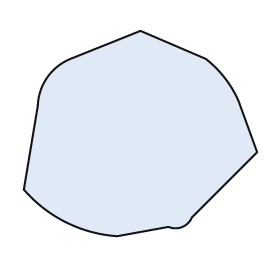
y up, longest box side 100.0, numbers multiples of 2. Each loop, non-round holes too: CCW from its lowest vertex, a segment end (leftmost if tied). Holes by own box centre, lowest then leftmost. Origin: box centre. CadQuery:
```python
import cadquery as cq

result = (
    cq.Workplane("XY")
    .moveTo(-10.0, -44.0)
    .lineTo(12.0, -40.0)
    .threePointArc((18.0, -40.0), (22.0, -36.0))
    .lineTo(50.0, -8.0)
    .lineTo(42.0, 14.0)
    .threePointArc((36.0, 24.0), (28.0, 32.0))
    .lineTo(0.0, 44.0)
    .lineTo(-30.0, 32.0)
    .threePointArc((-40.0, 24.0), (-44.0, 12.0))
    .lineTo(-50.0, -24.0)
    .threePointArc((-32.0, -38.0), (-10.0, -44.0))
    .close()
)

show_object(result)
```